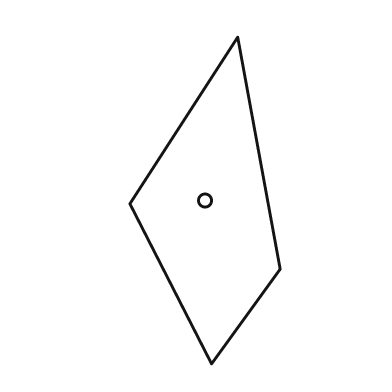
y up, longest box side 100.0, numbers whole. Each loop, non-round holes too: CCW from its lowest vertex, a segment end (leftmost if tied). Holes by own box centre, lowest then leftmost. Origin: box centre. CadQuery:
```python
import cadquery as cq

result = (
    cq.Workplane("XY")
    .moveTo(2.0, -50.0)
    .lineTo(23.0, -21.0)
    .lineTo(10.0, 50.0)
    .lineTo(-23.0, -1.0)
    .close()
    .moveTo(0.0, 0.0)
    .circle(2.0)
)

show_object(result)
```